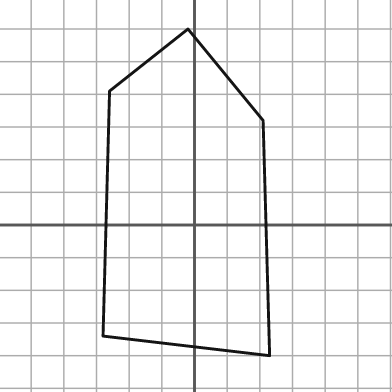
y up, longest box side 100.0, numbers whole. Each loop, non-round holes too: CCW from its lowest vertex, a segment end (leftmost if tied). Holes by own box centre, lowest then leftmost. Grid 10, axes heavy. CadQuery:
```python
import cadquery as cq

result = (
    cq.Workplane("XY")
    .moveTo(23.0, -40.0)
    .lineTo(21.0, 32.0)
    .lineTo(-2.0, 60.0)
    .lineTo(-26.0, 41.0)
    .lineTo(-28.0, -34.0)
    .close()
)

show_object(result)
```